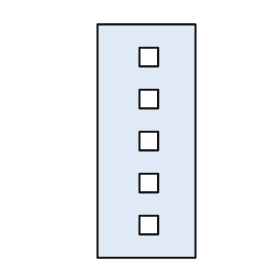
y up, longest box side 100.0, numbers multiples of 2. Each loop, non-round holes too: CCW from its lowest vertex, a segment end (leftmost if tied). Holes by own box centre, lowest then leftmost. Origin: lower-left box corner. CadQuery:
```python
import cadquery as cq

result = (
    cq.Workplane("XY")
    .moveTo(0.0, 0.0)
    .lineTo(42.0, 0.0)
    .lineTo(42.0, 100.0)
    .lineTo(0.0, 100.0)
    .close()
    .moveTo(18.0, 10.0)
    .lineTo(26.0, 10.0)
    .lineTo(26.0, 18.0)
    .lineTo(18.0, 18.0)
    .close()
    .moveTo(18.0, 28.0)
    .lineTo(26.0, 28.0)
    .lineTo(26.0, 36.0)
    .lineTo(18.0, 36.0)
    .close()
    .moveTo(18.0, 46.0)
    .lineTo(26.0, 46.0)
    .lineTo(26.0, 54.0)
    .lineTo(18.0, 54.0)
    .close()
    .moveTo(18.0, 64.0)
    .lineTo(26.0, 64.0)
    .lineTo(26.0, 72.0)
    .lineTo(18.0, 72.0)
    .close()
    .moveTo(18.0, 82.0)
    .lineTo(26.0, 82.0)
    .lineTo(26.0, 90.0)
    .lineTo(18.0, 90.0)
    .close()
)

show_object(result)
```